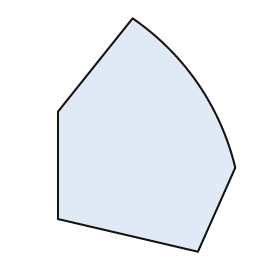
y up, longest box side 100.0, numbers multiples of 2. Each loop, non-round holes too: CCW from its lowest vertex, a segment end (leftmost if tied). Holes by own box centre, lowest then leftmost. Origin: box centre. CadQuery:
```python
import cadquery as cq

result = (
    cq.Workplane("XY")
    .moveTo(22.0, -50.0)
    .lineTo(38.0, -14.0)
    .threePointArc((22.0, 22.0), (-6.0, 50.0))
    .lineTo(-38.0, 10.0)
    .lineTo(-38.0, -36.0)
    .close()
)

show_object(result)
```